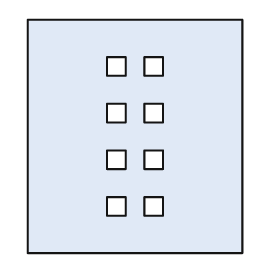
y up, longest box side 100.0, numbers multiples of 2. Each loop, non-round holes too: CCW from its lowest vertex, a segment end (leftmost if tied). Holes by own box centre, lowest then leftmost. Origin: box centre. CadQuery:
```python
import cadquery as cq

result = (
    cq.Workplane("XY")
    .moveTo(-46.0, -50.0)
    .lineTo(46.0, -50.0)
    .lineTo(46.0, 50.0)
    .lineTo(-46.0, 50.0)
    .close()
    .moveTo(-12.0, -34.0)
    .lineTo(-4.0, -34.0)
    .lineTo(-4.0, -26.0)
    .lineTo(-12.0, -26.0)
    .close()
    .moveTo(4.0, -34.0)
    .lineTo(12.0, -34.0)
    .lineTo(12.0, -26.0)
    .lineTo(4.0, -26.0)
    .close()
    .moveTo(-12.0, -14.0)
    .lineTo(-4.0, -14.0)
    .lineTo(-4.0, -6.0)
    .lineTo(-12.0, -6.0)
    .close()
    .moveTo(4.0, -14.0)
    .lineTo(12.0, -14.0)
    .lineTo(12.0, -6.0)
    .lineTo(4.0, -6.0)
    .close()
    .moveTo(-12.0, 6.0)
    .lineTo(-4.0, 6.0)
    .lineTo(-4.0, 14.0)
    .lineTo(-12.0, 14.0)
    .close()
    .moveTo(4.0, 6.0)
    .lineTo(12.0, 6.0)
    .lineTo(12.0, 14.0)
    .lineTo(4.0, 14.0)
    .close()
    .moveTo(-12.0, 26.0)
    .lineTo(-4.0, 26.0)
    .lineTo(-4.0, 34.0)
    .lineTo(-12.0, 34.0)
    .close()
    .moveTo(4.0, 26.0)
    .lineTo(12.0, 26.0)
    .lineTo(12.0, 34.0)
    .lineTo(4.0, 34.0)
    .close()
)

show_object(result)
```